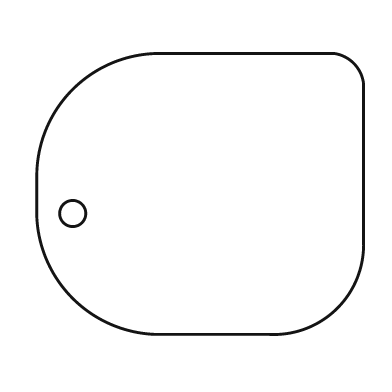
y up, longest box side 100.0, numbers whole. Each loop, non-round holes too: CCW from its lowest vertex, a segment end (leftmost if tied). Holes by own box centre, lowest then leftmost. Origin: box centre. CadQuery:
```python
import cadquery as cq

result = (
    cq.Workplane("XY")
    .moveTo(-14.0, -43.0)
    .lineTo(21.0, -43.0)
    .threePointArc((42.0, -35.0), (50.0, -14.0))
    .lineTo(50.0, 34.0)
    .threePointArc((47.0, 40.0), (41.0, 43.0))
    .lineTo(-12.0, 43.0)
    .threePointArc((-39.0, 32.0), (-50.0, 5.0))
    .lineTo(-50.0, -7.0)
    .threePointArc((-39.0, -32.0), (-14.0, -43.0))
    .close()
    .moveTo(-39.0, -6.0)
    .circle(4.0)
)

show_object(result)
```